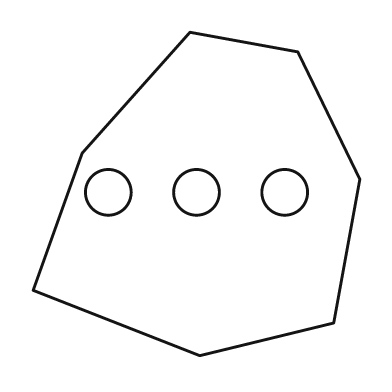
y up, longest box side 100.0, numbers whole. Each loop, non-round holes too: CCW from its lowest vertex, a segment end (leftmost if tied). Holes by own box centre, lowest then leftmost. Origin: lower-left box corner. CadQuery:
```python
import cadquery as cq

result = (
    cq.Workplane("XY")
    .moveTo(51.0, 0.0)
    .lineTo(92.0, 10.0)
    .lineTo(100.0, 54.0)
    .lineTo(81.0, 93.0)
    .lineTo(48.0, 99.0)
    .lineTo(15.0, 62.0)
    .lineTo(0.0, 20.0)
    .close()
    .moveTo(23.0, 50.0)
    .circle(7.0)
    .moveTo(50.0, 50.0)
    .circle(7.0)
    .moveTo(77.0, 50.0)
    .circle(7.0)
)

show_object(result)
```